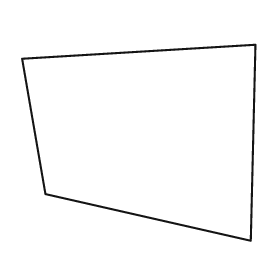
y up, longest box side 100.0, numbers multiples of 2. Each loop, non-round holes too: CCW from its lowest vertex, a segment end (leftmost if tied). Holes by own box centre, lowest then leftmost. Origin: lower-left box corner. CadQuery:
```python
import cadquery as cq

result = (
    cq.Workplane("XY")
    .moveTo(98.0, 0.0)
    .lineTo(100.0, 84.0)
    .lineTo(0.0, 78.0)
    .lineTo(10.0, 20.0)
    .close()
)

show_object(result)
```